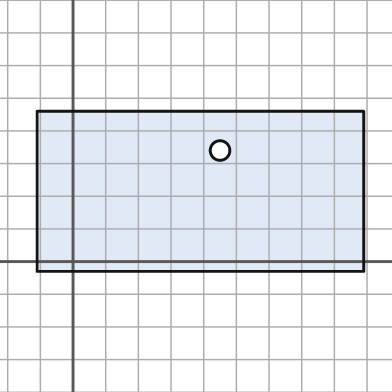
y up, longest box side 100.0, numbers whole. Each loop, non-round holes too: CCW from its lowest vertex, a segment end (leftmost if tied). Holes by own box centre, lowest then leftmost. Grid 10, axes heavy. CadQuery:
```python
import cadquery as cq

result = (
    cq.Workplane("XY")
    .moveTo(-11.0, -3.0)
    .lineTo(89.0, -3.0)
    .lineTo(89.0, 46.0)
    .lineTo(-11.0, 46.0)
    .close()
    .moveTo(45.0, 34.0)
    .circle(3.0)
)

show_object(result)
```